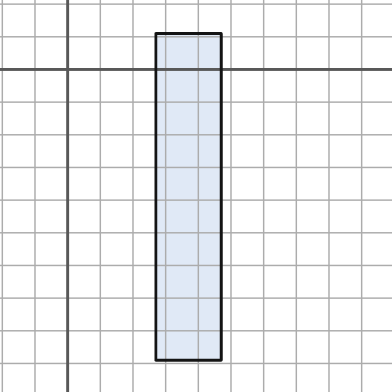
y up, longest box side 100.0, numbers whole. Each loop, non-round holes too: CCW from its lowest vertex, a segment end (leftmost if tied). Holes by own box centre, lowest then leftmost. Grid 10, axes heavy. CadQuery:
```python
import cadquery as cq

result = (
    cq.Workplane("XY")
    .moveTo(27.0, -89.0)
    .lineTo(47.0, -89.0)
    .lineTo(47.0, 11.0)
    .lineTo(27.0, 11.0)
    .close()
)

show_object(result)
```